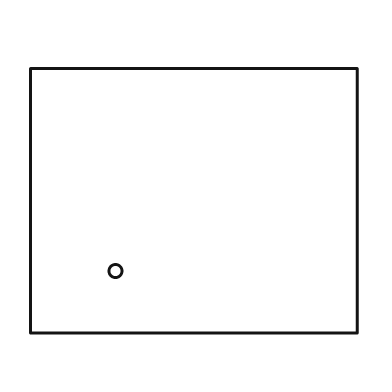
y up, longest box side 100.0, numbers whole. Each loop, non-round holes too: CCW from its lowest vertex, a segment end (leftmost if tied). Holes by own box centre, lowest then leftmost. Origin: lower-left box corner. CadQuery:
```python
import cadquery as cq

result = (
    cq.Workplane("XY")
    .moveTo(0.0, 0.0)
    .lineTo(100.0, 0.0)
    .lineTo(100.0, 81.0)
    .lineTo(0.0, 81.0)
    .close()
    .moveTo(26.0, 19.0)
    .circle(2.0)
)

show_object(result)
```